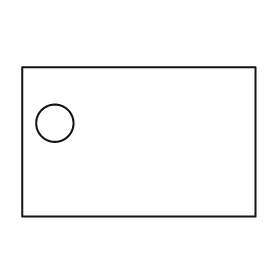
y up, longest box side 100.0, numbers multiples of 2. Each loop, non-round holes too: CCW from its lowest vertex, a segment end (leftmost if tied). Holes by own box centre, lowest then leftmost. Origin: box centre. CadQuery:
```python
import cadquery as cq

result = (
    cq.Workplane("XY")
    .moveTo(-50.0, -32.0)
    .lineTo(50.0, -32.0)
    .lineTo(50.0, 32.0)
    .lineTo(-50.0, 32.0)
    .close()
    .moveTo(-36.0, 8.0)
    .circle(8.0)
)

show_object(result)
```